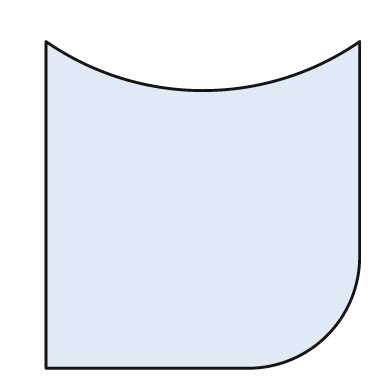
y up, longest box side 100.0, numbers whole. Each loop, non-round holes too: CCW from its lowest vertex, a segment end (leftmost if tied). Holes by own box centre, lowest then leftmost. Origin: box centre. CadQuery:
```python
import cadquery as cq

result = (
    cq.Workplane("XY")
    .moveTo(-48.0, -50.0)
    .lineTo(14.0, -50.0)
    .threePointArc((38.0, -40.0), (48.0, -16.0))
    .lineTo(48.0, 50.0)
    .threePointArc((0.0, 35.0), (-48.0, 50.0))
    .close()
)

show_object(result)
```